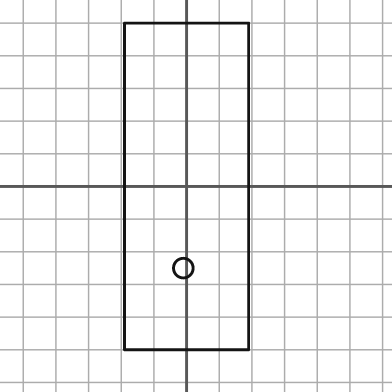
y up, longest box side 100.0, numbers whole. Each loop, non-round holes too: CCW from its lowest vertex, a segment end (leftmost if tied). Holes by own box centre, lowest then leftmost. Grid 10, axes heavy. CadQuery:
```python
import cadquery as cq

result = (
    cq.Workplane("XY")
    .moveTo(-19.0, -50.0)
    .lineTo(19.0, -50.0)
    .lineTo(19.0, 50.0)
    .lineTo(-19.0, 50.0)
    .close()
    .moveTo(-1.0, -25.0)
    .circle(3.0)
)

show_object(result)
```